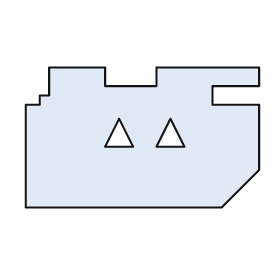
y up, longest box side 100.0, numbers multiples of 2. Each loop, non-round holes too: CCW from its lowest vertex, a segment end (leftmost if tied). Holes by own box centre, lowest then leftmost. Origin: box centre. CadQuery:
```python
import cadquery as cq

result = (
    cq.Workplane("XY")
    .moveTo(-50.0, -30.0)
    .lineTo(34.0, -30.0)
    .lineTo(50.0, -14.0)
    .lineTo(50.0, 14.0)
    .lineTo(30.0, 14.0)
    .lineTo(30.0, 22.0)
    .lineTo(50.0, 22.0)
    .lineTo(50.0, 30.0)
    .lineTo(6.0, 30.0)
    .lineTo(6.0, 22.0)
    .lineTo(-16.0, 22.0)
    .lineTo(-16.0, 30.0)
    .lineTo(-40.0, 30.0)
    .lineTo(-40.0, 18.0)
    .lineTo(-44.0, 18.0)
    .lineTo(-44.0, 14.0)
    .lineTo(-50.0, 14.0)
    .close()
    .moveTo(-16.0, -4.0)
    .lineTo(-4.0, -4.0)
    .lineTo(-10.0, 8.0)
    .close()
    .moveTo(6.0, -4.0)
    .lineTo(18.0, -4.0)
    .lineTo(12.0, 8.0)
    .close()
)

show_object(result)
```